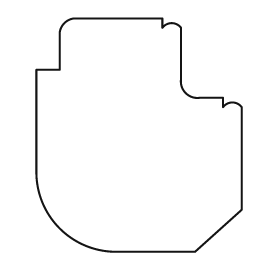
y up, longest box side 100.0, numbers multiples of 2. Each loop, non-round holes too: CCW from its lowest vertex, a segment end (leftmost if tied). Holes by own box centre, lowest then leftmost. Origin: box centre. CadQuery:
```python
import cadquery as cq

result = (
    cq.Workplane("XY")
    .moveTo(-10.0, -50.0)
    .lineTo(24.0, -50.0)
    .lineTo(44.0, -32.0)
    .lineTo(44.0, 12.0)
    .threePointArc((40.0, 14.0), (36.0, 12.0))
    .lineTo(36.0, 16.0)
    .lineTo(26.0, 16.0)
    .threePointArc((20.0, 18.0), (18.0, 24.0))
    .lineTo(18.0, 46.0)
    .threePointArc((14.0, 48.0), (10.0, 46.0))
    .lineTo(10.0, 50.0)
    .lineTo(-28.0, 50.0)
    .threePointArc((-32.0, 48.0), (-34.0, 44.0))
    .lineTo(-34.0, 28.0)
    .lineTo(-44.0, 28.0)
    .lineTo(-44.0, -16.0)
    .threePointArc((-34.0, -40.0), (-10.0, -50.0))
    .close()
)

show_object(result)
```